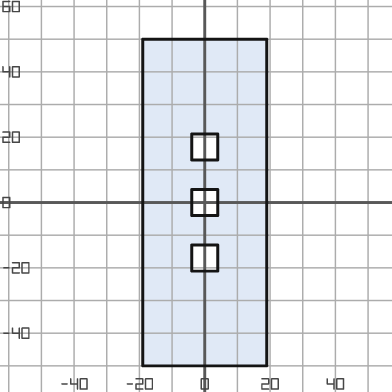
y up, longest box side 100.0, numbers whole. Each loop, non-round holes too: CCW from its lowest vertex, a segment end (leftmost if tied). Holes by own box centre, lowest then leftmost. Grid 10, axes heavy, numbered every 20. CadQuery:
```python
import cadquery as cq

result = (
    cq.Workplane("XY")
    .moveTo(-19.0, -50.0)
    .lineTo(19.0, -50.0)
    .lineTo(19.0, 50.0)
    .lineTo(-19.0, 50.0)
    .close()
    .moveTo(-4.0, -21.0)
    .lineTo(4.0, -21.0)
    .lineTo(4.0, -13.0)
    .lineTo(-4.0, -13.0)
    .close()
    .moveTo(-4.0, -4.0)
    .lineTo(4.0, -4.0)
    .lineTo(4.0, 4.0)
    .lineTo(-4.0, 4.0)
    .close()
    .moveTo(-4.0, 13.0)
    .lineTo(4.0, 13.0)
    .lineTo(4.0, 21.0)
    .lineTo(-4.0, 21.0)
    .close()
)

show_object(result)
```